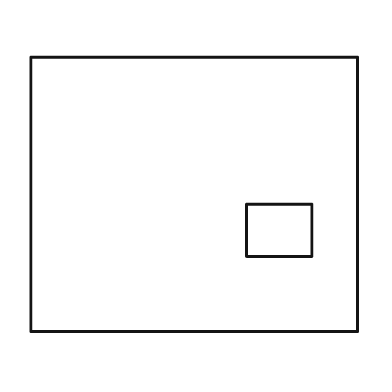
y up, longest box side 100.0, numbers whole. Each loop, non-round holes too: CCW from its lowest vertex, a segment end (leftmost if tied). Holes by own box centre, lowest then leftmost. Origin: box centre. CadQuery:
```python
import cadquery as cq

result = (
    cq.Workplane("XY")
    .moveTo(-50.0, -42.0)
    .lineTo(50.0, -42.0)
    .lineTo(50.0, 42.0)
    .lineTo(-50.0, 42.0)
    .close()
    .moveTo(16.0, -19.0)
    .lineTo(36.0, -19.0)
    .lineTo(36.0, -3.0)
    .lineTo(16.0, -3.0)
    .close()
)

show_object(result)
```